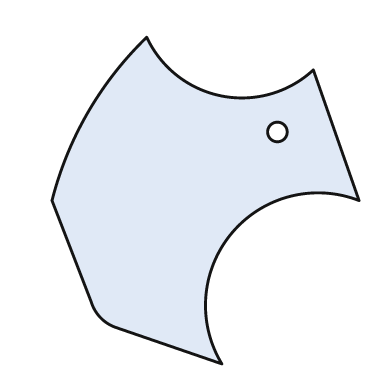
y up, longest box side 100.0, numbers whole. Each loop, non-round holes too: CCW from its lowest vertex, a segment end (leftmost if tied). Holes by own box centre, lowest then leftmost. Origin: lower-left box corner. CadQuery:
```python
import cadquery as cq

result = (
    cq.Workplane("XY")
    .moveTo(52.0, 0.0)
    .threePointArc((55.0, 40.0), (94.0, 50.0))
    .lineTo(80.0, 90.0)
    .threePointArc((52.0, 82.0), (29.0, 100.0))
    .threePointArc((11.0, 77.0), (0.0, 50.0))
    .lineTo(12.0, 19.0)
    .threePointArc((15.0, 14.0), (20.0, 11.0))
    .close()
    .moveTo(69.0, 71.0)
    .circle(3.0)
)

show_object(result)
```